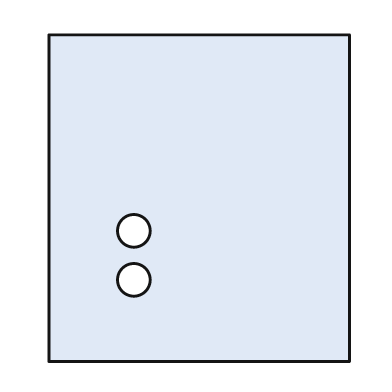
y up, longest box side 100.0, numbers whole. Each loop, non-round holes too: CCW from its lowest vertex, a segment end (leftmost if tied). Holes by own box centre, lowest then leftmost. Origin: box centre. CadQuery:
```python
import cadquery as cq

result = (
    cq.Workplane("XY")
    .moveTo(-46.0, -50.0)
    .lineTo(46.0, -50.0)
    .lineTo(46.0, 50.0)
    .lineTo(-46.0, 50.0)
    .close()
    .moveTo(-20.0, -25.0)
    .circle(5.0)
    .moveTo(-20.0, -10.0)
    .circle(5.0)
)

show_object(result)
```